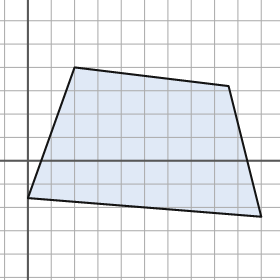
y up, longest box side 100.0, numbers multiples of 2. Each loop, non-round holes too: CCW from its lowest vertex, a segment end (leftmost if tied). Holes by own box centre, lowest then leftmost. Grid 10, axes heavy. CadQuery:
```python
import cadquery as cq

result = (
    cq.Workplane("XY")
    .moveTo(100.0, -24.0)
    .lineTo(86.0, 32.0)
    .lineTo(20.0, 40.0)
    .lineTo(0.0, -16.0)
    .close()
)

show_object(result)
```